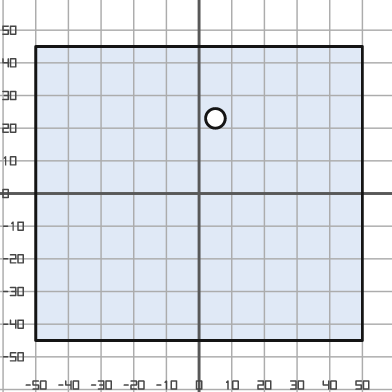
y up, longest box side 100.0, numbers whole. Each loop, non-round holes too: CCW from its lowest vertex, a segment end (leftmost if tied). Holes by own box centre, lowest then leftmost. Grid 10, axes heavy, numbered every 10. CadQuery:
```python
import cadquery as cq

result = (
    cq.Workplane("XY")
    .moveTo(-50.0, -45.0)
    .lineTo(50.0, -45.0)
    .lineTo(50.0, 45.0)
    .lineTo(-50.0, 45.0)
    .close()
    .moveTo(5.0, 23.0)
    .circle(3.0)
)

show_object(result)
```